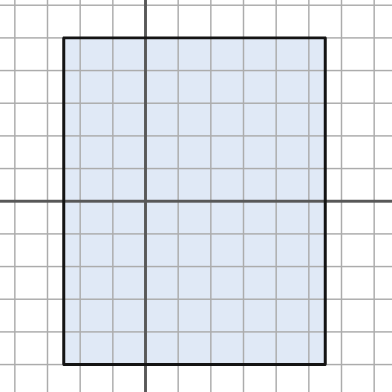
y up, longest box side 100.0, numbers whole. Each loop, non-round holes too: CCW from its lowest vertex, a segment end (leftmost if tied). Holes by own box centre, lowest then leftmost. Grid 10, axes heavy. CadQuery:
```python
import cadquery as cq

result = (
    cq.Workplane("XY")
    .moveTo(-25.0, -50.0)
    .lineTo(55.0, -50.0)
    .lineTo(55.0, 50.0)
    .lineTo(-25.0, 50.0)
    .close()
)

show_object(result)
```